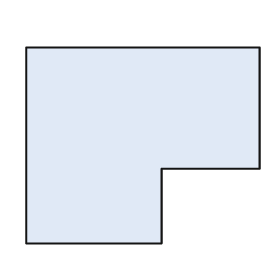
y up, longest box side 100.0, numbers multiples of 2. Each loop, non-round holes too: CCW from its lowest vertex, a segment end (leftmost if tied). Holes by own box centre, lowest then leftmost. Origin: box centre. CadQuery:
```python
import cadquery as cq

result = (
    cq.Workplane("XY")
    .moveTo(-50.0, -42.0)
    .lineTo(8.0, -42.0)
    .lineTo(8.0, -10.0)
    .lineTo(50.0, -10.0)
    .lineTo(50.0, 42.0)
    .lineTo(-50.0, 42.0)
    .close()
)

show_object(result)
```